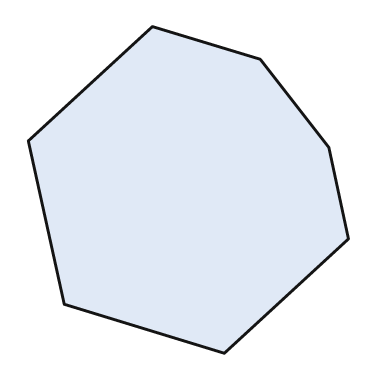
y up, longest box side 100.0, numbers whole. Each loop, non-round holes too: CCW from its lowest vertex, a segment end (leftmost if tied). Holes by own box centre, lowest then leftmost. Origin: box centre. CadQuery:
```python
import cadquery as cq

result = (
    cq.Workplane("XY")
    .moveTo(11.0, -50.0)
    .lineTo(49.0, -15.0)
    .lineTo(43.0, 13.0)
    .lineTo(22.0, 40.0)
    .lineTo(-11.0, 50.0)
    .lineTo(-49.0, 15.0)
    .lineTo(-38.0, -35.0)
    .close()
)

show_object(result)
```